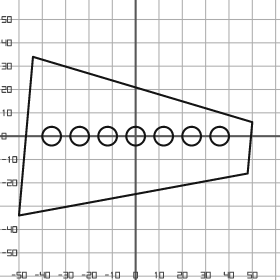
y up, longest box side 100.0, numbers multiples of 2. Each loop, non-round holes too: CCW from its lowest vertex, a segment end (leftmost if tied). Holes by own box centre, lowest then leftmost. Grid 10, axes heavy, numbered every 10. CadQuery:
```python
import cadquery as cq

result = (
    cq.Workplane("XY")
    .moveTo(-50.0, -34.0)
    .lineTo(48.0, -16.0)
    .lineTo(50.0, 6.0)
    .lineTo(-44.0, 34.0)
    .close()
    .moveTo(-36.0, 0.0)
    .circle(4.0)
    .moveTo(-24.0, 0.0)
    .circle(4.0)
    .moveTo(-12.0, 0.0)
    .circle(4.0)
    .moveTo(0.0, 0.0)
    .circle(4.0)
    .moveTo(12.0, 0.0)
    .circle(4.0)
    .moveTo(24.0, 0.0)
    .circle(4.0)
    .moveTo(36.0, 0.0)
    .circle(4.0)
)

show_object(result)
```